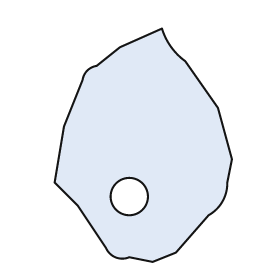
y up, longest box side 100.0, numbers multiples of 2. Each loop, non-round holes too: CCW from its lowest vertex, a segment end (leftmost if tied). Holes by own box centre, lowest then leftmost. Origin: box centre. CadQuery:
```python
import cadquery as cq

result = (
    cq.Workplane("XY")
    .moveTo(4.0, -50.0)
    .lineTo(14.0, -46.0)
    .lineTo(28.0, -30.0)
    .threePointArc((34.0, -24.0), (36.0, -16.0))
    .lineTo(38.0, -6.0)
    .lineTo(32.0, 16.0)
    .lineTo(18.0, 36.0)
    .threePointArc((12.0, 42.0), (8.0, 50.0))
    .lineTo(-10.0, 42.0)
    .lineTo(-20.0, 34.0)
    .threePointArc((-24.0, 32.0), (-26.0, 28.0))
    .lineTo(-34.0, 8.0)
    .lineTo(-38.0, -16.0)
    .lineTo(-28.0, -26.0)
    .lineTo(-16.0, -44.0)
    .threePointArc((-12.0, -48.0), (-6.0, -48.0))
    .close()
    .moveTo(-6.0, -22.0)
    .circle(8.0)
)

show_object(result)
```